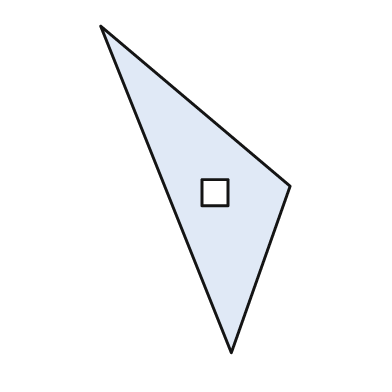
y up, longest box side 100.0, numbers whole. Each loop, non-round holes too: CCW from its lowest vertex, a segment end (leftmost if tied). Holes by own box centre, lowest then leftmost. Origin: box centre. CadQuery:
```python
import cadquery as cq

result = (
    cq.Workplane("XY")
    .moveTo(11.0, -50.0)
    .lineTo(29.0, 1.0)
    .lineTo(-29.0, 50.0)
    .close()
    .moveTo(2.0, -5.0)
    .lineTo(10.0, -5.0)
    .lineTo(10.0, 3.0)
    .lineTo(2.0, 3.0)
    .close()
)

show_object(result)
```